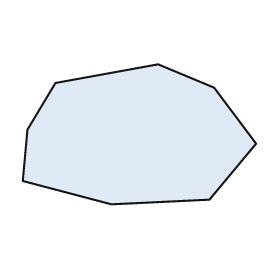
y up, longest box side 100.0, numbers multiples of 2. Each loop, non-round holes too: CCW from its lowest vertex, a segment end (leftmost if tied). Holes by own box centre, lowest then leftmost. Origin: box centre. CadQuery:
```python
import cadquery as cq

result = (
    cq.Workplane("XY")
    .moveTo(-12.0, -30.0)
    .lineTo(30.0, -28.0)
    .lineTo(50.0, -4.0)
    .lineTo(32.0, 20.0)
    .lineTo(8.0, 30.0)
    .lineTo(-36.0, 22.0)
    .lineTo(-48.0, 2.0)
    .lineTo(-50.0, -20.0)
    .close()
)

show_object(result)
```